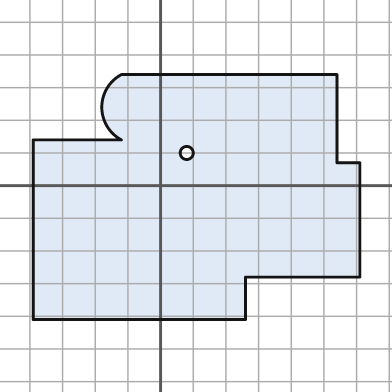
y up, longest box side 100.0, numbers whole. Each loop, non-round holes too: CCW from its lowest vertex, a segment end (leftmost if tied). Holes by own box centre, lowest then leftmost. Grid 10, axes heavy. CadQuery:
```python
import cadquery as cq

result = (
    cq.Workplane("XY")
    .moveTo(-39.0, -41.0)
    .lineTo(26.0, -41.0)
    .lineTo(26.0, -28.0)
    .lineTo(61.0, -28.0)
    .lineTo(61.0, 7.0)
    .lineTo(54.0, 7.0)
    .lineTo(54.0, 34.0)
    .lineTo(-12.0, 34.0)
    .threePointArc((-18.0, 24.0), (-12.0, 14.0))
    .lineTo(-39.0, 14.0)
    .close()
    .moveTo(8.0, 10.0)
    .circle(2.0)
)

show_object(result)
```